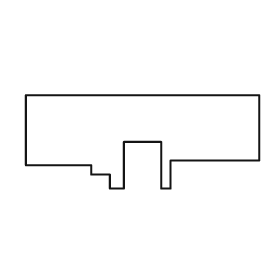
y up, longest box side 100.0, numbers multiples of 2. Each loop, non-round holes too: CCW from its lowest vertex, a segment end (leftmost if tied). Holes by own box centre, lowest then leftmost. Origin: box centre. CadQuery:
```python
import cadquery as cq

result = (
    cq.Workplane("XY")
    .moveTo(-14.0, -20.0)
    .lineTo(-8.0, -20.0)
    .lineTo(-8.0, 0.0)
    .lineTo(8.0, 0.0)
    .lineTo(8.0, -20.0)
    .lineTo(12.0, -20.0)
    .lineTo(12.0, -8.0)
    .lineTo(50.0, -8.0)
    .lineTo(50.0, 20.0)
    .lineTo(-50.0, 20.0)
    .lineTo(-50.0, -10.0)
    .lineTo(-22.0, -10.0)
    .lineTo(-22.0, -14.0)
    .lineTo(-14.0, -14.0)
    .close()
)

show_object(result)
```